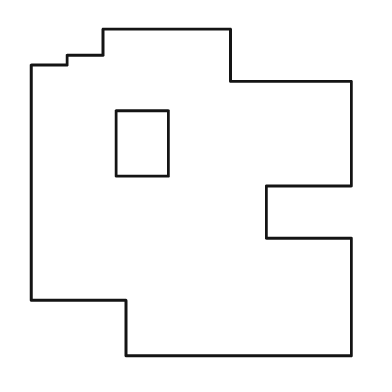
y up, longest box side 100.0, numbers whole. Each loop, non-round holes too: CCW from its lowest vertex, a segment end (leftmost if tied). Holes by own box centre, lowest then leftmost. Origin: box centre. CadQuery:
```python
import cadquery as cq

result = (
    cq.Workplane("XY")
    .moveTo(-20.0, -50.0)
    .lineTo(49.0, -50.0)
    .lineTo(49.0, -14.0)
    .lineTo(23.0, -14.0)
    .lineTo(23.0, 2.0)
    .lineTo(49.0, 2.0)
    .lineTo(49.0, 34.0)
    .lineTo(12.0, 34.0)
    .lineTo(12.0, 50.0)
    .lineTo(-27.0, 50.0)
    .lineTo(-27.0, 42.0)
    .lineTo(-38.0, 42.0)
    .lineTo(-38.0, 39.0)
    .lineTo(-49.0, 39.0)
    .lineTo(-49.0, -33.0)
    .lineTo(-20.0, -33.0)
    .close()
    .moveTo(-23.0, 5.0)
    .lineTo(-7.0, 5.0)
    .lineTo(-7.0, 25.0)
    .lineTo(-23.0, 25.0)
    .close()
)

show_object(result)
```